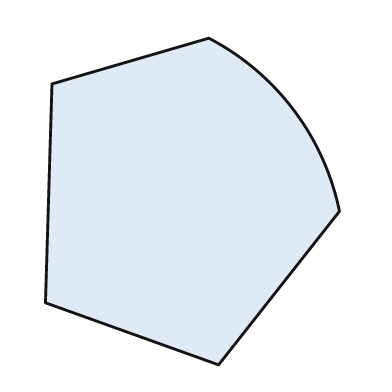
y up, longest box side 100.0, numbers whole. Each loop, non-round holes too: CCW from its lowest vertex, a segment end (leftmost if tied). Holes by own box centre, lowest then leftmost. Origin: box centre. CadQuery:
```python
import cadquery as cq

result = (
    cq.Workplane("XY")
    .moveTo(8.0, -50.0)
    .lineTo(45.0, -3.0)
    .threePointArc((31.0, 28.0), (5.0, 50.0))
    .lineTo(-43.0, 36.0)
    .lineTo(-45.0, -31.0)
    .close()
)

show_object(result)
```